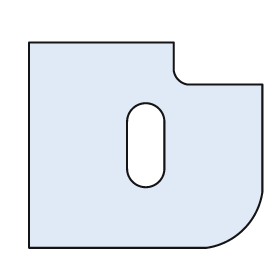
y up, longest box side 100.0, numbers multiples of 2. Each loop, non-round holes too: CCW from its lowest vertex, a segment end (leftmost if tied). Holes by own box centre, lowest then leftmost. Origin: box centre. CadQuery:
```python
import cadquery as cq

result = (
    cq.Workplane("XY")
    .moveTo(-50.0, -44.0)
    .lineTo(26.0, -44.0)
    .threePointArc((42.0, -36.0), (50.0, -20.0))
    .lineTo(50.0, 26.0)
    .lineTo(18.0, 26.0)
    .threePointArc((14.0, 28.0), (12.0, 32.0))
    .lineTo(12.0, 44.0)
    .lineTo(-50.0, 44.0)
    .close()
    .moveTo(-8.0, -10.0)
    .threePointArc((0.0, -18.0), (8.0, -10.0))
    .lineTo(8.0, 10.0)
    .threePointArc((0.0, 18.0), (-8.0, 10.0))
    .close()
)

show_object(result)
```